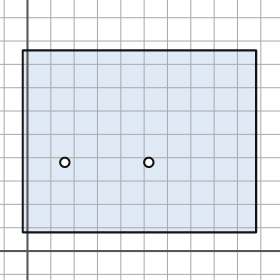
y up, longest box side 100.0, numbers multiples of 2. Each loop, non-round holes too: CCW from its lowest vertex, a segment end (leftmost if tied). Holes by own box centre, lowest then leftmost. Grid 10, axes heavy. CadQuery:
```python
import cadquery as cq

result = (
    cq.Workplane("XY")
    .moveTo(-2.0, 8.0)
    .lineTo(98.0, 8.0)
    .lineTo(98.0, 86.0)
    .lineTo(-2.0, 86.0)
    .close()
    .moveTo(16.0, 38.0)
    .circle(2.0)
    .moveTo(52.0, 38.0)
    .circle(2.0)
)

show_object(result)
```